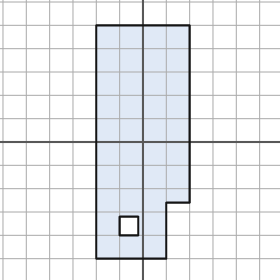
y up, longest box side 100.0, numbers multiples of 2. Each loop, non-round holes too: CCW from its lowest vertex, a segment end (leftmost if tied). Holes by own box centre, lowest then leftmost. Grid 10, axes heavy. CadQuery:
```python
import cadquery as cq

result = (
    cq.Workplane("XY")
    .moveTo(-20.0, -50.0)
    .lineTo(10.0, -50.0)
    .lineTo(10.0, -26.0)
    .lineTo(20.0, -26.0)
    .lineTo(20.0, 50.0)
    .lineTo(-20.0, 50.0)
    .close()
    .moveTo(-10.0, -40.0)
    .lineTo(-2.0, -40.0)
    .lineTo(-2.0, -32.0)
    .lineTo(-10.0, -32.0)
    .close()
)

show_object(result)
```